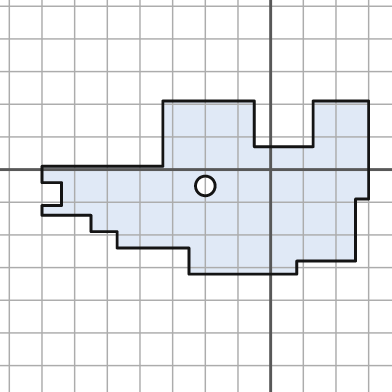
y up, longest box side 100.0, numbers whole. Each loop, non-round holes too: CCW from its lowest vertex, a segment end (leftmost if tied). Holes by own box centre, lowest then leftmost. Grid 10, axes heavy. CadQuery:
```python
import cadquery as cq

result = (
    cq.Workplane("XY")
    .moveTo(-25.0, -32.0)
    .lineTo(8.0, -32.0)
    .lineTo(8.0, -28.0)
    .lineTo(26.0, -28.0)
    .lineTo(26.0, -9.0)
    .lineTo(30.0, -9.0)
    .lineTo(30.0, 21.0)
    .lineTo(13.0, 21.0)
    .lineTo(13.0, 7.0)
    .lineTo(-5.0, 7.0)
    .lineTo(-5.0, 21.0)
    .lineTo(-33.0, 21.0)
    .lineTo(-33.0, 1.0)
    .lineTo(-70.0, 1.0)
    .lineTo(-70.0, -4.0)
    .lineTo(-64.0, -4.0)
    .lineTo(-64.0, -11.0)
    .lineTo(-70.0, -11.0)
    .lineTo(-70.0, -14.0)
    .lineTo(-55.0, -14.0)
    .lineTo(-55.0, -19.0)
    .lineTo(-47.0, -19.0)
    .lineTo(-47.0, -24.0)
    .lineTo(-25.0, -24.0)
    .close()
    .moveTo(-20.0, -5.0)
    .circle(3.0)
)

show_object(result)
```